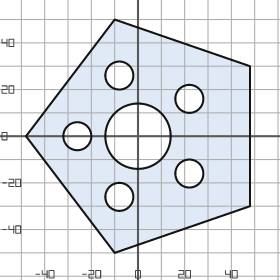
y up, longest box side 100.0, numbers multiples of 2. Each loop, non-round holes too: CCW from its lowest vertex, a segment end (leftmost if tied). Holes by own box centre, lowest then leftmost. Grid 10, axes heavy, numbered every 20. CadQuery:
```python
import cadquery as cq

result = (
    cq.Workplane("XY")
    .moveTo(-10.0, -50.0)
    .lineTo(48.0, -30.0)
    .lineTo(48.0, 30.0)
    .lineTo(-10.0, 50.0)
    .lineTo(-48.0, 0.0)
    .close()
    .moveTo(-8.0, -26.0)
    .circle(6.0)
    .moveTo(22.0, -16.0)
    .circle(6.0)
    .moveTo(-26.0, 0.0)
    .circle(6.0)
    .moveTo(0.0, 0.0)
    .circle(14.0)
    .moveTo(22.0, 16.0)
    .circle(6.0)
    .moveTo(-8.0, 26.0)
    .circle(6.0)
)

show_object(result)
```